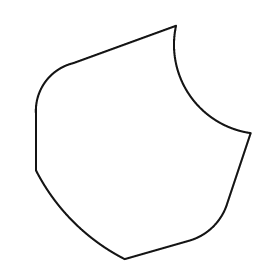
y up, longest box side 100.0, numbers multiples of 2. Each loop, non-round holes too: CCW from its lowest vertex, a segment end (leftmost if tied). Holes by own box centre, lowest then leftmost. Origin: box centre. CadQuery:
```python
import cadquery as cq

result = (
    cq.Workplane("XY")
    .moveTo(-8.0, -50.0)
    .lineTo(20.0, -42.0)
    .threePointArc((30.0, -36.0), (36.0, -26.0))
    .lineTo(46.0, 4.0)
    .threePointArc((20.0, 20.0), (14.0, 50.0))
    .lineTo(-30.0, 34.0)
    .threePointArc((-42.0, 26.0), (-46.0, 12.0))
    .lineTo(-46.0, -12.0)
    .threePointArc((-30.0, -34.0), (-8.0, -50.0))
    .close()
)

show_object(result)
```